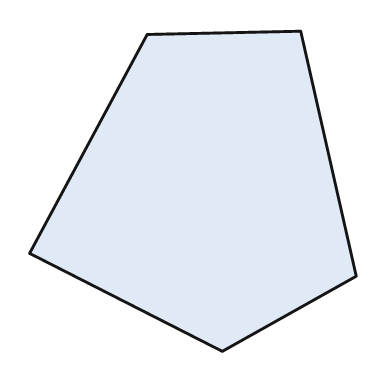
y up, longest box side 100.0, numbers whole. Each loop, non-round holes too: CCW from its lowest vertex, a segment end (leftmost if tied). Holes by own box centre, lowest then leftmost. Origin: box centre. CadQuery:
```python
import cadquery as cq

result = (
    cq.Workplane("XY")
    .moveTo(9.0, -49.0)
    .lineTo(50.0, -26.0)
    .lineTo(33.0, 49.0)
    .lineTo(-14.0, 48.0)
    .lineTo(-50.0, -19.0)
    .close()
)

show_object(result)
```